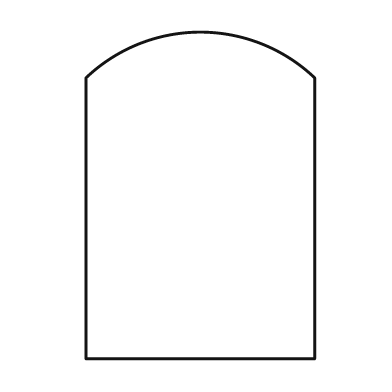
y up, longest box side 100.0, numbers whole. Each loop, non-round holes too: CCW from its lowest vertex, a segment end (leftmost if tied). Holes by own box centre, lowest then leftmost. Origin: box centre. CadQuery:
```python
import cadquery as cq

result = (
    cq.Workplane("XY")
    .moveTo(-35.0, -50.0)
    .lineTo(35.0, -50.0)
    .lineTo(35.0, 36.0)
    .threePointArc((0.0, 50.0), (-35.0, 36.0))
    .close()
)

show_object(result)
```